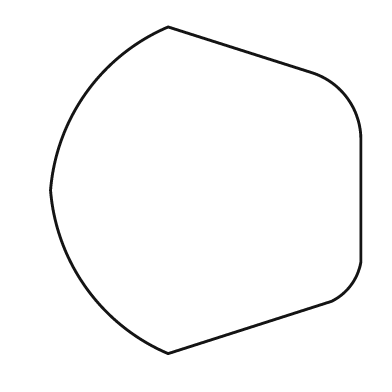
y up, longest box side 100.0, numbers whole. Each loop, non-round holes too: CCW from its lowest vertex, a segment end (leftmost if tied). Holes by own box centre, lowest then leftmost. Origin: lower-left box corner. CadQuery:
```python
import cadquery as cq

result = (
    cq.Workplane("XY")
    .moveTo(36.0, 0.0)
    .lineTo(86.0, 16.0)
    .threePointArc((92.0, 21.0), (95.0, 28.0))
    .lineTo(95.0, 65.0)
    .threePointArc((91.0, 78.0), (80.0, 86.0))
    .lineTo(36.0, 100.0)
    .threePointArc((11.0, 80.0), (0.0, 50.0))
    .threePointArc((11.0, 20.0), (36.0, 0.0))
    .close()
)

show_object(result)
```